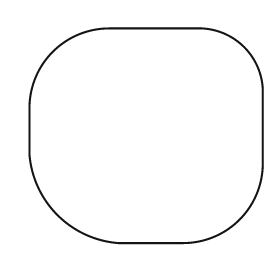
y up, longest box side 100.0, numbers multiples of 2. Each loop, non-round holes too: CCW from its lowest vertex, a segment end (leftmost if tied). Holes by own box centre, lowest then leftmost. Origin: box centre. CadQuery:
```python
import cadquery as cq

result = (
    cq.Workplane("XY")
    .moveTo(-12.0, -46.0)
    .lineTo(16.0, -46.0)
    .threePointArc((40.0, -36.0), (50.0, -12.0))
    .lineTo(50.0, 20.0)
    .threePointArc((42.0, 38.0), (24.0, 46.0))
    .lineTo(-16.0, 46.0)
    .threePointArc((-40.0, 36.0), (-50.0, 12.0))
    .lineTo(-50.0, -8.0)
    .threePointArc((-38.0, -34.0), (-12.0, -46.0))
    .close()
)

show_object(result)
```